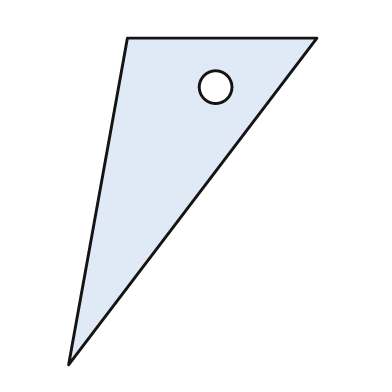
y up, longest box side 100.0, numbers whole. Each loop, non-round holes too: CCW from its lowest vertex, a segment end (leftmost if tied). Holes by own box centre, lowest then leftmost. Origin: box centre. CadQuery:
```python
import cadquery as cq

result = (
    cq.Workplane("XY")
    .moveTo(-38.0, -50.0)
    .lineTo(38.0, 50.0)
    .lineTo(-20.0, 50.0)
    .close()
    .moveTo(7.0, 35.0)
    .circle(5.0)
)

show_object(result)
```